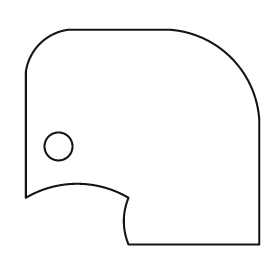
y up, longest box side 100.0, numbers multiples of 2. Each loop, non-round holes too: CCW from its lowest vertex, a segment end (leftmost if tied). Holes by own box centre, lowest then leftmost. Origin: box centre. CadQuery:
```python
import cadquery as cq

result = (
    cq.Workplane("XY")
    .moveTo(-6.0, -46.0)
    .lineTo(50.0, -46.0)
    .lineTo(50.0, 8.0)
    .threePointArc((38.0, 34.0), (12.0, 46.0))
    .lineTo(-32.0, 46.0)
    .threePointArc((-44.0, 40.0), (-50.0, 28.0))
    .lineTo(-50.0, -26.0)
    .threePointArc((-28.0, -20.0), (-6.0, -26.0))
    .threePointArc((-8.0, -36.0), (-6.0, -46.0))
    .close()
    .moveTo(-36.0, -4.0)
    .circle(6.0)
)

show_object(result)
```